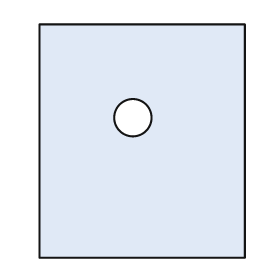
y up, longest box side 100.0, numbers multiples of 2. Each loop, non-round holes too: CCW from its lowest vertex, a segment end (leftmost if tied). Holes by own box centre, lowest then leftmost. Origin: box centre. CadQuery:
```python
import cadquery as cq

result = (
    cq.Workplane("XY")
    .moveTo(-44.0, -50.0)
    .lineTo(44.0, -50.0)
    .lineTo(44.0, 50.0)
    .lineTo(-44.0, 50.0)
    .close()
    .moveTo(-4.0, 10.0)
    .circle(8.0)
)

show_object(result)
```